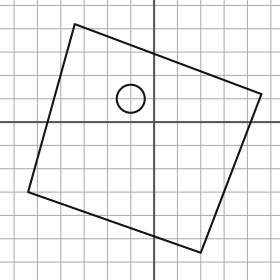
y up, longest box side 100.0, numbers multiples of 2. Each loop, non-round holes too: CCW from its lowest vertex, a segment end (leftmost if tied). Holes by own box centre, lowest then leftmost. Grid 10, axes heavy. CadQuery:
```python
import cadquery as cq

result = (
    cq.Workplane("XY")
    .moveTo(20.0, -56.0)
    .lineTo(46.0, 12.0)
    .lineTo(-34.0, 42.0)
    .lineTo(-54.0, -30.0)
    .close()
    .moveTo(-10.0, 10.0)
    .circle(6.0)
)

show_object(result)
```